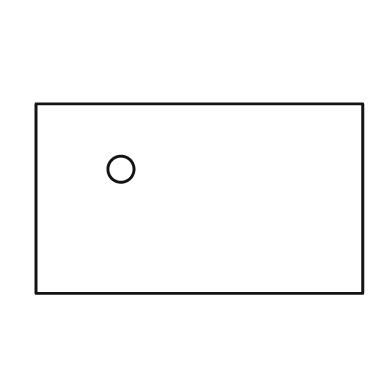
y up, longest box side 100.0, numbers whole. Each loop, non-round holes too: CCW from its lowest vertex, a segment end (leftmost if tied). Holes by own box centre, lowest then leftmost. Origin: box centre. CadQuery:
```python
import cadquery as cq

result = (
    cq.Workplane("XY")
    .moveTo(-50.0, -29.0)
    .lineTo(50.0, -29.0)
    .lineTo(50.0, 29.0)
    .lineTo(-50.0, 29.0)
    .close()
    .moveTo(-24.0, 9.0)
    .circle(4.0)
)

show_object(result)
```